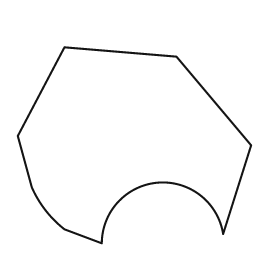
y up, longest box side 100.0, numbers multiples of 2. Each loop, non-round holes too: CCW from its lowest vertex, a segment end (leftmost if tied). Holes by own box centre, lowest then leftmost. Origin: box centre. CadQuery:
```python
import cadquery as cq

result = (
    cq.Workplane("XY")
    .moveTo(-14.0, -42.0)
    .threePointArc((10.0, -16.0), (38.0, -38.0))
    .lineTo(50.0, 0.0)
    .lineTo(18.0, 38.0)
    .lineTo(-30.0, 42.0)
    .lineTo(-50.0, 4.0)
    .lineTo(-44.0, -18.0)
    .threePointArc((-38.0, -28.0), (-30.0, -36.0))
    .close()
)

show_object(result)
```